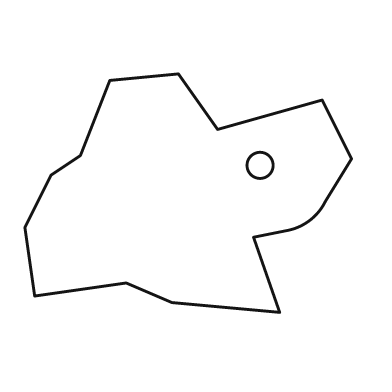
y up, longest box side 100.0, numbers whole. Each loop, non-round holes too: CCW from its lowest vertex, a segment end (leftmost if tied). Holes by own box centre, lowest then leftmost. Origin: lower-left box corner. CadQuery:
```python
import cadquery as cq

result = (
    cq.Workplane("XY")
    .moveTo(78.0, 0.0)
    .lineTo(70.0, 23.0)
    .lineTo(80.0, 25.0)
    .threePointArc((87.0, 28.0), (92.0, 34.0))
    .lineTo(100.0, 47.0)
    .lineTo(91.0, 65.0)
    .lineTo(59.0, 56.0)
    .lineTo(47.0, 73.0)
    .lineTo(26.0, 71.0)
    .lineTo(17.0, 48.0)
    .lineTo(8.0, 42.0)
    .lineTo(0.0, 26.0)
    .lineTo(3.0, 5.0)
    .lineTo(31.0, 9.0)
    .lineTo(45.0, 3.0)
    .close()
    .moveTo(72.0, 45.0)
    .circle(4.0)
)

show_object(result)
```